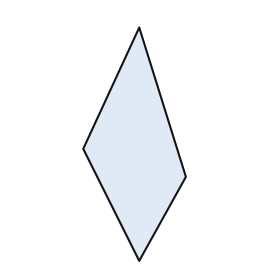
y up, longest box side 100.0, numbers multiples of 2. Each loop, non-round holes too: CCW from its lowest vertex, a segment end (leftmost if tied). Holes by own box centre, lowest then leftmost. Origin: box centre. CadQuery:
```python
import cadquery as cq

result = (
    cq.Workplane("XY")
    .moveTo(2.0, -50.0)
    .lineTo(22.0, -14.0)
    .lineTo(2.0, 50.0)
    .lineTo(-22.0, -2.0)
    .close()
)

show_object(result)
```